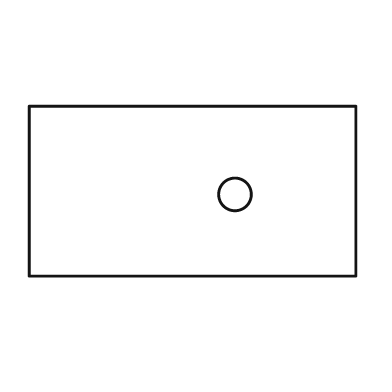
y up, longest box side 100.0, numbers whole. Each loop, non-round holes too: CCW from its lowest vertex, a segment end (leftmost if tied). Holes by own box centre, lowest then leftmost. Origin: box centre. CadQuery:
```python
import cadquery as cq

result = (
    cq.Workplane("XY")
    .moveTo(-50.0, -26.0)
    .lineTo(50.0, -26.0)
    .lineTo(50.0, 26.0)
    .lineTo(-50.0, 26.0)
    .close()
    .moveTo(13.0, -1.0)
    .circle(5.0)
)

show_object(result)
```